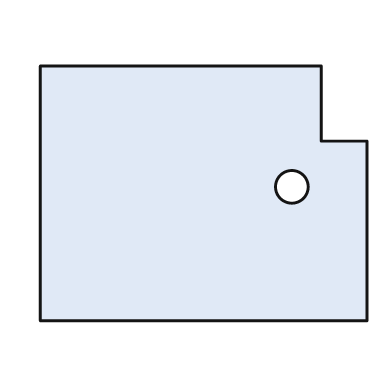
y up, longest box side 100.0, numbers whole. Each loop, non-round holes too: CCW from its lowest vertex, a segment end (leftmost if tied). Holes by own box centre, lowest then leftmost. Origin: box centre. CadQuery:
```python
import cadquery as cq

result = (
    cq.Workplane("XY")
    .moveTo(-50.0, -39.0)
    .lineTo(50.0, -39.0)
    .lineTo(50.0, 16.0)
    .lineTo(36.0, 16.0)
    .lineTo(36.0, 39.0)
    .lineTo(-50.0, 39.0)
    .close()
    .moveTo(27.0, 2.0)
    .circle(5.0)
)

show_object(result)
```